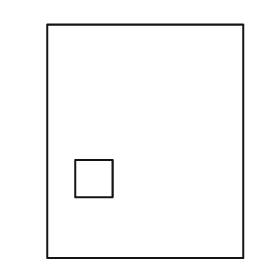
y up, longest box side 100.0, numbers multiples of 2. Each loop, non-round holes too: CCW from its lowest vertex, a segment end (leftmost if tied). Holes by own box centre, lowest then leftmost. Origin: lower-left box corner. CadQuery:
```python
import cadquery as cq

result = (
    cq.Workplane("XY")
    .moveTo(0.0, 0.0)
    .lineTo(84.0, 0.0)
    .lineTo(84.0, 100.0)
    .lineTo(0.0, 100.0)
    .close()
    .moveTo(12.0, 26.0)
    .lineTo(28.0, 26.0)
    .lineTo(28.0, 42.0)
    .lineTo(12.0, 42.0)
    .close()
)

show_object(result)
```